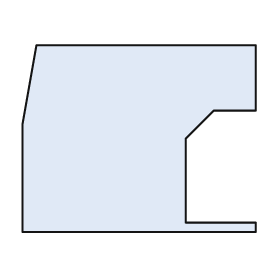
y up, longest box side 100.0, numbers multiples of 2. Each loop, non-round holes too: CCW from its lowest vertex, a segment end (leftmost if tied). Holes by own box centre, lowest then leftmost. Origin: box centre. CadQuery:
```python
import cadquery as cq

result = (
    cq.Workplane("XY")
    .moveTo(-50.0, -40.0)
    .lineTo(50.0, -40.0)
    .lineTo(50.0, -36.0)
    .lineTo(20.0, -36.0)
    .lineTo(20.0, 0.0)
    .lineTo(32.0, 12.0)
    .lineTo(50.0, 12.0)
    .lineTo(50.0, 40.0)
    .lineTo(-44.0, 40.0)
    .lineTo(-50.0, 6.0)
    .close()
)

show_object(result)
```